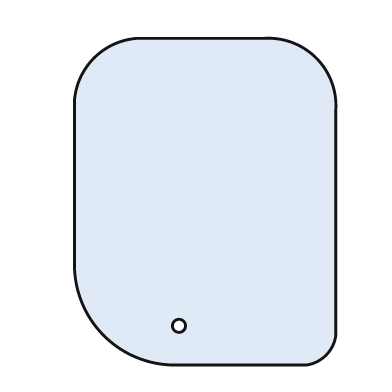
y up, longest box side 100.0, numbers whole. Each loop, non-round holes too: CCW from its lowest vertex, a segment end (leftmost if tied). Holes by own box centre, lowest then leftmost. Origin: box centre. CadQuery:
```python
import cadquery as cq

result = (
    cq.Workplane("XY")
    .moveTo(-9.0, -50.0)
    .lineTo(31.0, -50.0)
    .threePointArc((37.0, -47.0), (40.0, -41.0))
    .lineTo(40.0, 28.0)
    .threePointArc((34.0, 44.0), (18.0, 50.0))
    .lineTo(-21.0, 50.0)
    .threePointArc((-34.0, 44.0), (-40.0, 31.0))
    .lineTo(-40.0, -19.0)
    .threePointArc((-31.0, -41.0), (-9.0, -50.0))
    .close()
    .moveTo(-8.0, -38.0)
    .circle(2.0)
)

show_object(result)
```